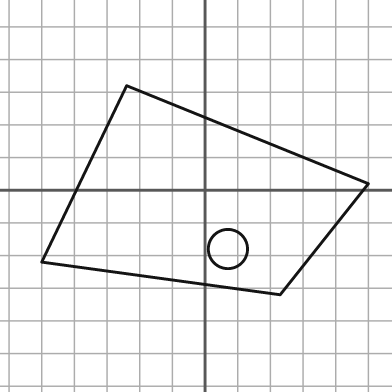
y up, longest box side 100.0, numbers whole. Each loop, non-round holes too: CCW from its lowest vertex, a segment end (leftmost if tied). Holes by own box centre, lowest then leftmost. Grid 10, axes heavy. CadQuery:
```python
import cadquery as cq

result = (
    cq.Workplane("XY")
    .moveTo(23.0, -32.0)
    .lineTo(50.0, 2.0)
    .lineTo(-24.0, 32.0)
    .lineTo(-50.0, -22.0)
    .close()
    .moveTo(7.0, -18.0)
    .circle(6.0)
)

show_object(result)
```